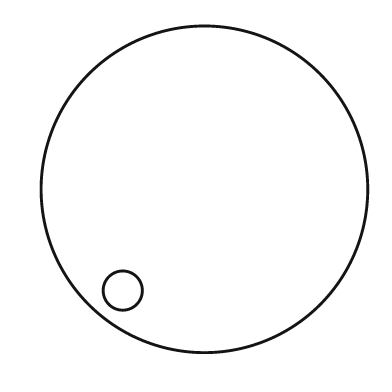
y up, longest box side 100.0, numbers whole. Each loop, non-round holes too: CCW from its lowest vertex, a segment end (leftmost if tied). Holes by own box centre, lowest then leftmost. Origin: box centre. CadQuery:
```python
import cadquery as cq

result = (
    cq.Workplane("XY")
    .moveTo(0.0, 0.0)
    .circle(50.0)
    .moveTo(-25.0, -31.0)
    .circle(6.0)
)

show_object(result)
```